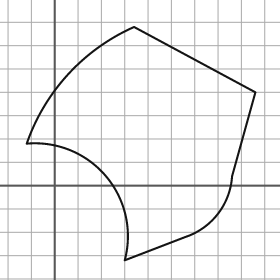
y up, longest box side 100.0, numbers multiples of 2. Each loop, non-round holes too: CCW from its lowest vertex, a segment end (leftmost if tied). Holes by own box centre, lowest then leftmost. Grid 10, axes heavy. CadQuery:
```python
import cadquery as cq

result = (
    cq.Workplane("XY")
    .moveTo(30.0, -32.0)
    .lineTo(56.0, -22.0)
    .threePointArc((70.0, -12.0), (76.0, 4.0))
    .lineTo(86.0, 40.0)
    .lineTo(34.0, 68.0)
    .threePointArc((6.0, 48.0), (-12.0, 18.0))
    .threePointArc((22.0, 4.0), (30.0, -32.0))
    .close()
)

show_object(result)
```